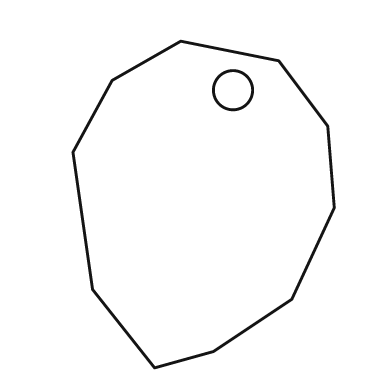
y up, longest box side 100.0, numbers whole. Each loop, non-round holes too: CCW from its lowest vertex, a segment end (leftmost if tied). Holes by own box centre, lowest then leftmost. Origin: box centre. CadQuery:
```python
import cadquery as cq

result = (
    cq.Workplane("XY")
    .moveTo(-15.0, -50.0)
    .lineTo(3.0, -45.0)
    .lineTo(27.0, -29.0)
    .lineTo(40.0, -1.0)
    .lineTo(38.0, 24.0)
    .lineTo(23.0, 44.0)
    .lineTo(-7.0, 50.0)
    .lineTo(-28.0, 38.0)
    .lineTo(-40.0, 16.0)
    .lineTo(-34.0, -26.0)
    .close()
    .moveTo(9.0, 35.0)
    .circle(6.0)
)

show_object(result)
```